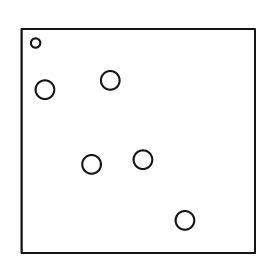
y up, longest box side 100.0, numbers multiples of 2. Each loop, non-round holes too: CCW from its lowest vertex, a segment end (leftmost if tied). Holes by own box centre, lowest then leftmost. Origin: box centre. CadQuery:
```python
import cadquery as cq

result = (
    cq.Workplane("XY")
    .moveTo(-50.0, -48.0)
    .lineTo(50.0, -48.0)
    .lineTo(50.0, 48.0)
    .lineTo(-50.0, 48.0)
    .close()
    .moveTo(20.0, -34.0)
    .circle(4.0)
    .moveTo(-20.0, -10.0)
    .circle(4.0)
    .moveTo(2.0, -8.0)
    .circle(4.0)
    .moveTo(-40.0, 22.0)
    .circle(4.0)
    .moveTo(-12.0, 26.0)
    .circle(4.0)
    .moveTo(-44.0, 42.0)
    .circle(2.0)
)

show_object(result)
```